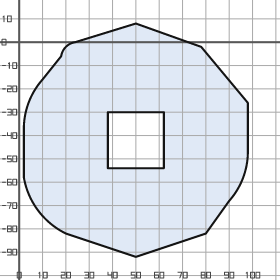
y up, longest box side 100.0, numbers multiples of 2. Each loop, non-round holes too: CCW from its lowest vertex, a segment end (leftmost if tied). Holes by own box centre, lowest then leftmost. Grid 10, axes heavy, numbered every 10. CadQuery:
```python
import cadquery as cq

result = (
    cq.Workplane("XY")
    .moveTo(50.0, -92.0)
    .lineTo(80.0, -82.0)
    .lineTo(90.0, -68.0)
    .threePointArc((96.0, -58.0), (98.0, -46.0))
    .lineTo(98.0, -26.0)
    .lineTo(78.0, -2.0)
    .lineTo(50.0, 8.0)
    .lineTo(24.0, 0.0)
    .threePointArc((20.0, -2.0), (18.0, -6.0))
    .lineTo(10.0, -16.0)
    .threePointArc((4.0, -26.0), (2.0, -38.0))
    .lineTo(2.0, -58.0)
    .threePointArc((8.0, -72.0), (20.0, -82.0))
    .close()
    .moveTo(38.0, -54.0)
    .lineTo(62.0, -54.0)
    .lineTo(62.0, -30.0)
    .lineTo(38.0, -30.0)
    .close()
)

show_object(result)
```